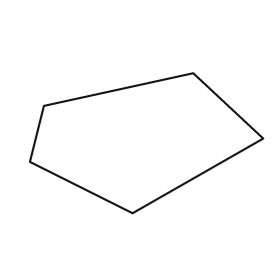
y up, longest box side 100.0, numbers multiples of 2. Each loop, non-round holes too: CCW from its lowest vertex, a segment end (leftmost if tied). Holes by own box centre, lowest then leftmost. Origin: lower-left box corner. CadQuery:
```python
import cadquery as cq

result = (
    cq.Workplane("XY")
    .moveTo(44.0, 0.0)
    .lineTo(100.0, 32.0)
    .lineTo(70.0, 60.0)
    .lineTo(6.0, 46.0)
    .lineTo(0.0, 22.0)
    .close()
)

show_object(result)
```